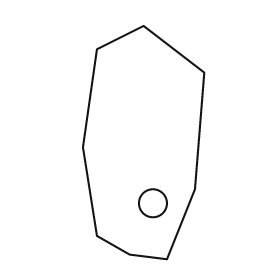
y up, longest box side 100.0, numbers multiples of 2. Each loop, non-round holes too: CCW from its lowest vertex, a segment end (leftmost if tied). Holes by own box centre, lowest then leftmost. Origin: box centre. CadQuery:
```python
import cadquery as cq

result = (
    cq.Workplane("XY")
    .moveTo(10.0, -50.0)
    .lineTo(22.0, -20.0)
    .lineTo(26.0, 30.0)
    .lineTo(0.0, 50.0)
    .lineTo(-20.0, 40.0)
    .lineTo(-26.0, -2.0)
    .lineTo(-20.0, -40.0)
    .lineTo(-6.0, -48.0)
    .close()
    .moveTo(4.0, -26.0)
    .circle(6.0)
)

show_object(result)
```